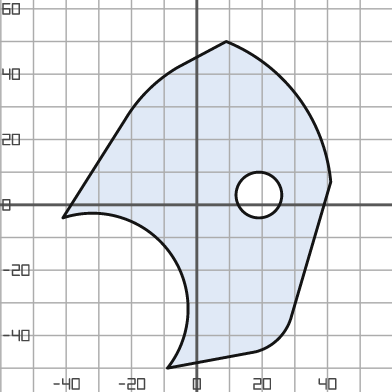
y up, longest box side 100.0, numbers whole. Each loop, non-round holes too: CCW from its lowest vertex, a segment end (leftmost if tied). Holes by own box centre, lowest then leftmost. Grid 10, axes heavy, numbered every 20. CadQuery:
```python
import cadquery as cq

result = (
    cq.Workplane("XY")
    .moveTo(-9.0, -50.0)
    .lineTo(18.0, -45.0)
    .threePointArc((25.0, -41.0), (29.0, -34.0))
    .lineTo(41.0, 7.0)
    .threePointArc((31.0, 33.0), (9.0, 50.0))
    .lineTo(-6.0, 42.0)
    .threePointArc((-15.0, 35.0), (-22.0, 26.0))
    .lineTo(-41.0, -4.0)
    .threePointArc((-8.0, -15.0), (-9.0, -50.0))
    .close()
    .moveTo(19.0, 3.0)
    .circle(7.0)
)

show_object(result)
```